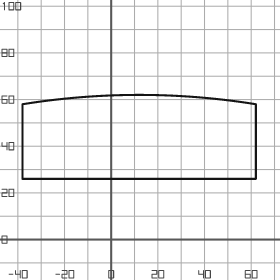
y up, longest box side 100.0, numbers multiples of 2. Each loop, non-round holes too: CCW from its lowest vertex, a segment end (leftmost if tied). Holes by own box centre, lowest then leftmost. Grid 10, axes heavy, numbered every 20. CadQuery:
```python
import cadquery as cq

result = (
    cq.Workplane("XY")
    .moveTo(-38.0, 26.0)
    .lineTo(62.0, 26.0)
    .lineTo(62.0, 58.0)
    .threePointArc((12.0, 62.0), (-38.0, 58.0))
    .close()
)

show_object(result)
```